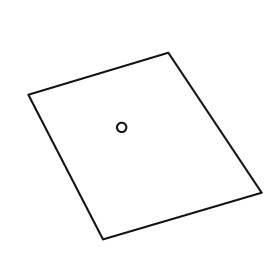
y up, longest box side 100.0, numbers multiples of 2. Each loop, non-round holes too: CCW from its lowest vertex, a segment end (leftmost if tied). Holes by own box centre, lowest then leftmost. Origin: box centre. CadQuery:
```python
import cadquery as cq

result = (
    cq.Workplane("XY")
    .moveTo(-18.0, -40.0)
    .lineTo(50.0, -20.0)
    .lineTo(10.0, 40.0)
    .lineTo(-50.0, 22.0)
    .close()
    .moveTo(-10.0, 8.0)
    .circle(2.0)
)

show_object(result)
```